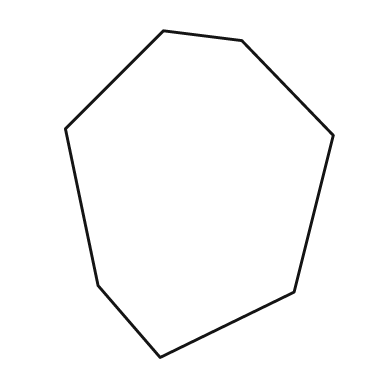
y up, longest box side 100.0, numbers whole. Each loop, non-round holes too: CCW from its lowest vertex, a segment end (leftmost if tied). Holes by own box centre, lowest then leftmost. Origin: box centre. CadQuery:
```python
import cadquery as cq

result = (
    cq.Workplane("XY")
    .moveTo(-12.0, -50.0)
    .lineTo(29.0, -30.0)
    .lineTo(41.0, 18.0)
    .lineTo(13.0, 47.0)
    .lineTo(-11.0, 50.0)
    .lineTo(-41.0, 20.0)
    .lineTo(-31.0, -28.0)
    .close()
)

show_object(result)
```